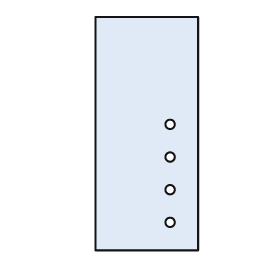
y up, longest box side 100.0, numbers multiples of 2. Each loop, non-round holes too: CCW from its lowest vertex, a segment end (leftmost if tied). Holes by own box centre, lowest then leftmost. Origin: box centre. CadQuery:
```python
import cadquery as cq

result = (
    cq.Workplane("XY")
    .moveTo(-22.0, -50.0)
    .lineTo(22.0, -50.0)
    .lineTo(22.0, 50.0)
    .lineTo(-22.0, 50.0)
    .close()
    .moveTo(10.0, -38.0)
    .circle(2.0)
    .moveTo(10.0, -24.0)
    .circle(2.0)
    .moveTo(10.0, -10.0)
    .circle(2.0)
    .moveTo(10.0, 4.0)
    .circle(2.0)
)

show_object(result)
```